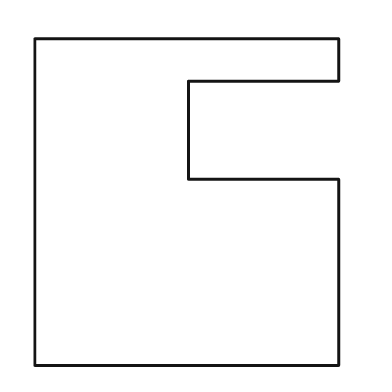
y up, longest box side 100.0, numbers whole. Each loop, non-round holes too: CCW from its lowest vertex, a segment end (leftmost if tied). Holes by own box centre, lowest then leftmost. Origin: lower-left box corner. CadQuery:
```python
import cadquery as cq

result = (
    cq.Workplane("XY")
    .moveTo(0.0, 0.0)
    .lineTo(93.0, 0.0)
    .lineTo(93.0, 57.0)
    .lineTo(47.0, 57.0)
    .lineTo(47.0, 87.0)
    .lineTo(93.0, 87.0)
    .lineTo(93.0, 100.0)
    .lineTo(0.0, 100.0)
    .close()
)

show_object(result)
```